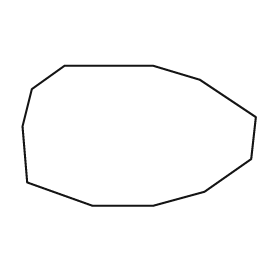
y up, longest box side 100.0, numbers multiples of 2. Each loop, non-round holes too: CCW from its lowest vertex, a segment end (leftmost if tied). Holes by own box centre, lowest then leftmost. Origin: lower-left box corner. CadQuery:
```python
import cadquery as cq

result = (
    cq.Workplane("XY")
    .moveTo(30.0, 0.0)
    .lineTo(56.0, 0.0)
    .lineTo(78.0, 6.0)
    .lineTo(98.0, 20.0)
    .lineTo(100.0, 38.0)
    .lineTo(76.0, 54.0)
    .lineTo(56.0, 60.0)
    .lineTo(18.0, 60.0)
    .lineTo(4.0, 50.0)
    .lineTo(0.0, 34.0)
    .lineTo(2.0, 10.0)
    .close()
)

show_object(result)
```